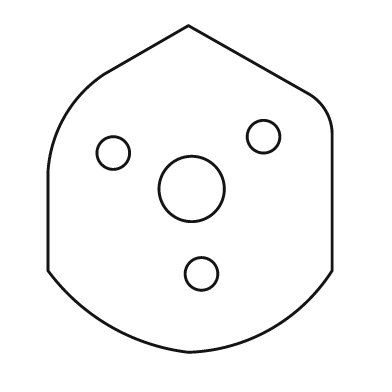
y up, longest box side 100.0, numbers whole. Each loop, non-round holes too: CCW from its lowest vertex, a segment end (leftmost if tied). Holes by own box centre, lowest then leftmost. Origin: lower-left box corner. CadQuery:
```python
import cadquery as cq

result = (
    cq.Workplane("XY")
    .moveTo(43.0, 0.0)
    .threePointArc((68.0, 7.0), (87.0, 25.0))
    .lineTo(87.0, 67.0)
    .threePointArc((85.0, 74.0), (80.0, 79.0))
    .lineTo(43.0, 100.0)
    .lineTo(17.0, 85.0)
    .threePointArc((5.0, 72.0), (0.0, 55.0))
    .lineTo(0.0, 25.0)
    .threePointArc((19.0, 8.0), (43.0, 0.0))
    .close()
    .moveTo(47.0, 24.0)
    .circle(5.0)
    .moveTo(44.0, 50.0)
    .circle(10.0)
    .moveTo(20.0, 61.0)
    .circle(5.0)
    .moveTo(66.0, 66.0)
    .circle(5.0)
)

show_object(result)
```